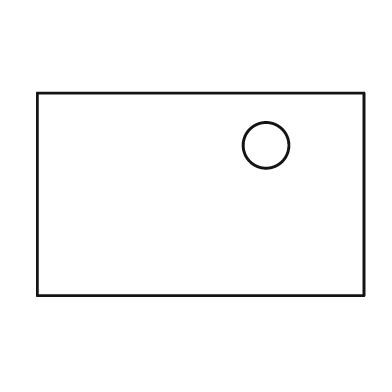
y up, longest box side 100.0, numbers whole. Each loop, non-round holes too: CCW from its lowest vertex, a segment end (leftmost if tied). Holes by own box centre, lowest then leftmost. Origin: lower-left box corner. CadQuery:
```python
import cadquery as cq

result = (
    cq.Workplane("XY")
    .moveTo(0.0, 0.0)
    .lineTo(100.0, 0.0)
    .lineTo(100.0, 62.0)
    .lineTo(0.0, 62.0)
    .close()
    .moveTo(70.0, 46.0)
    .circle(7.0)
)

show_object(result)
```